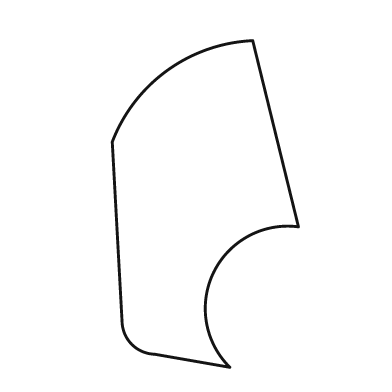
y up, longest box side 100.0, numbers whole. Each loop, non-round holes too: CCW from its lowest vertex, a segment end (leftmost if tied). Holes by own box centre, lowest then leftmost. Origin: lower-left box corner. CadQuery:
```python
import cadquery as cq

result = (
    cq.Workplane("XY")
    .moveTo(36.0, 0.0)
    .threePointArc((31.0, 29.0), (57.0, 43.0))
    .lineTo(43.0, 100.0)
    .threePointArc((17.0, 91.0), (0.0, 69.0))
    .lineTo(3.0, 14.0)
    .threePointArc((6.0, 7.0), (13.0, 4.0))
    .close()
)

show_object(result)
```